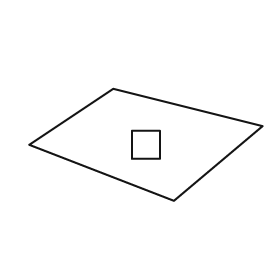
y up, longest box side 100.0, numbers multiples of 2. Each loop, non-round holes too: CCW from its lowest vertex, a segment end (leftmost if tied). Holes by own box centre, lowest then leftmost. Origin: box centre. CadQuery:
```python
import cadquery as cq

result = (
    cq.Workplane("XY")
    .moveTo(12.0, -24.0)
    .lineTo(50.0, 8.0)
    .lineTo(-14.0, 24.0)
    .lineTo(-50.0, 0.0)
    .close()
    .moveTo(-6.0, -6.0)
    .lineTo(6.0, -6.0)
    .lineTo(6.0, 6.0)
    .lineTo(-6.0, 6.0)
    .close()
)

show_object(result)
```